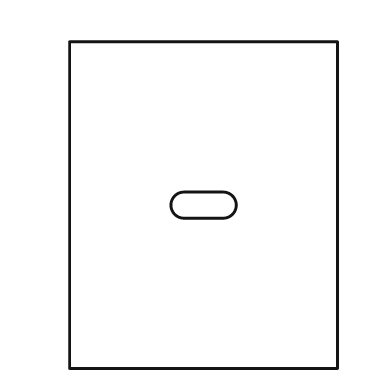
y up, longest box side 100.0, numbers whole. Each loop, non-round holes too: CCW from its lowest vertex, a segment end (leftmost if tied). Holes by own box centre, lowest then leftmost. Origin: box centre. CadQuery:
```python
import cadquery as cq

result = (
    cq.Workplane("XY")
    .moveTo(-41.0, -50.0)
    .lineTo(41.0, -50.0)
    .lineTo(41.0, 50.0)
    .lineTo(-41.0, 50.0)
    .close()
    .moveTo(-6.0, -4.0)
    .lineTo(6.0, -4.0)
    .threePointArc((10.0, 0.0), (6.0, 4.0))
    .lineTo(-6.0, 4.0)
    .threePointArc((-10.0, 0.0), (-6.0, -4.0))
    .close()
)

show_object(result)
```